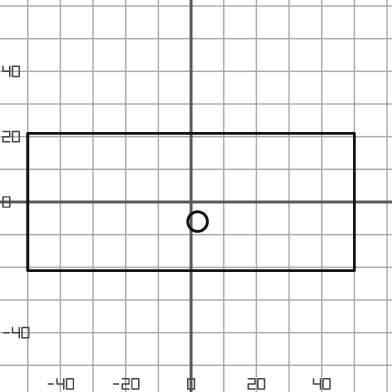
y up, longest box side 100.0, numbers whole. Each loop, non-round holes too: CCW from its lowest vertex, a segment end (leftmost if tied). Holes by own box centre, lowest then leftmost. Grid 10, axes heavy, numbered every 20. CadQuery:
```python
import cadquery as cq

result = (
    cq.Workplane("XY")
    .moveTo(-50.0, -21.0)
    .lineTo(50.0, -21.0)
    .lineTo(50.0, 21.0)
    .lineTo(-50.0, 21.0)
    .close()
    .moveTo(2.0, -6.0)
    .circle(3.0)
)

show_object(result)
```